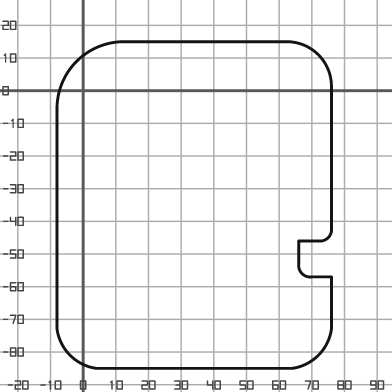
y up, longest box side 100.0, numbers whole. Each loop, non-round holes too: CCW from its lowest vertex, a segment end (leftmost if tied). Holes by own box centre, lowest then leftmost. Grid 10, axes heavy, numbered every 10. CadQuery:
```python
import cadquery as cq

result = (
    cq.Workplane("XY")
    .moveTo(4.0, -85.0)
    .lineTo(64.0, -85.0)
    .threePointArc((72.0, -81.0), (76.0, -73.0))
    .lineTo(76.0, -57.0)
    .lineTo(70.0, -57.0)
    .threePointArc((67.0, -56.0), (66.0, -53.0))
    .lineTo(66.0, -46.0)
    .lineTo(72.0, -46.0)
    .threePointArc((75.0, -45.0), (76.0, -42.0))
    .lineTo(76.0, 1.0)
    .threePointArc((72.0, 11.0), (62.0, 15.0))
    .lineTo(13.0, 15.0)
    .threePointArc((-2.0, 9.0), (-8.0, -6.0))
    .lineTo(-8.0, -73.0)
    .threePointArc((-4.0, -81.0), (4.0, -85.0))
    .close()
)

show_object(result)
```